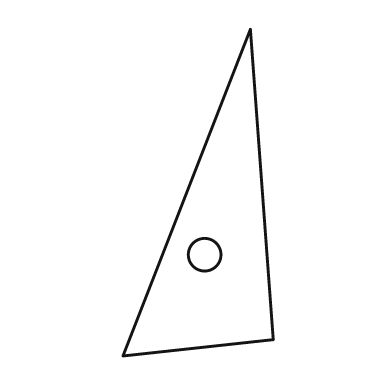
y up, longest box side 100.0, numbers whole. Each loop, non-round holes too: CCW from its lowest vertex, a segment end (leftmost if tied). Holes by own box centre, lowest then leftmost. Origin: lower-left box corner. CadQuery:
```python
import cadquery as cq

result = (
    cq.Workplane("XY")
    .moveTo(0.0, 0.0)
    .lineTo(46.0, 5.0)
    .lineTo(39.0, 100.0)
    .close()
    .moveTo(25.0, 31.0)
    .circle(5.0)
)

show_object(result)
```